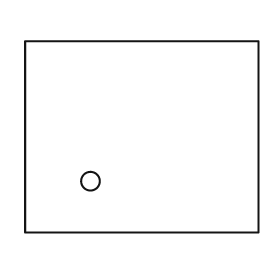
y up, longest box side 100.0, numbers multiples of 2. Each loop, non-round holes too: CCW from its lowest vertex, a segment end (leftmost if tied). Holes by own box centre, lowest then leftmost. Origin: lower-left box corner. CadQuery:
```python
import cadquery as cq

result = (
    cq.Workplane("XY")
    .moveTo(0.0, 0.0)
    .lineTo(100.0, 0.0)
    .lineTo(100.0, 82.0)
    .lineTo(0.0, 82.0)
    .close()
    .moveTo(28.0, 22.0)
    .circle(4.0)
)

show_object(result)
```